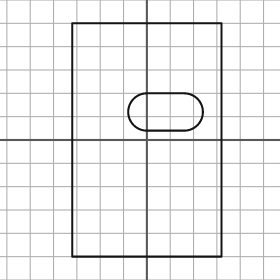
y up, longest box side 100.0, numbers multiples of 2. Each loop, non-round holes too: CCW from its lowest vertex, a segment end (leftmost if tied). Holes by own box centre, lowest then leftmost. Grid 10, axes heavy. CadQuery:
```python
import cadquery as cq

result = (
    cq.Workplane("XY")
    .moveTo(-32.0, -50.0)
    .lineTo(32.0, -50.0)
    .lineTo(32.0, 50.0)
    .lineTo(-32.0, 50.0)
    .close()
    .moveTo(0.0, 4.0)
    .lineTo(16.0, 4.0)
    .threePointArc((24.0, 12.0), (16.0, 20.0))
    .lineTo(0.0, 20.0)
    .threePointArc((-8.0, 12.0), (0.0, 4.0))
    .close()
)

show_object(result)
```